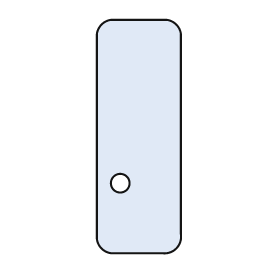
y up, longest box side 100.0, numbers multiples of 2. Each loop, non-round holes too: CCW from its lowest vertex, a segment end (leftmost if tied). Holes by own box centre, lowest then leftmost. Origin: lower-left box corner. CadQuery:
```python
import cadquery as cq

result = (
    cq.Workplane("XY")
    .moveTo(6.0, 0.0)
    .lineTo(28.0, 0.0)
    .threePointArc((34.0, 2.0), (36.0, 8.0))
    .lineTo(36.0, 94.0)
    .threePointArc((34.0, 98.0), (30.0, 100.0))
    .lineTo(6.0, 100.0)
    .threePointArc((2.0, 98.0), (0.0, 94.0))
    .lineTo(0.0, 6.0)
    .threePointArc((2.0, 2.0), (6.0, 0.0))
    .close()
    .moveTo(10.0, 30.0)
    .circle(4.0)
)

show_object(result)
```